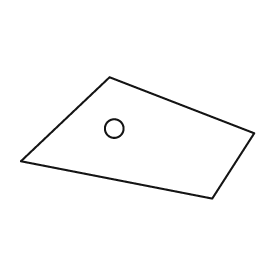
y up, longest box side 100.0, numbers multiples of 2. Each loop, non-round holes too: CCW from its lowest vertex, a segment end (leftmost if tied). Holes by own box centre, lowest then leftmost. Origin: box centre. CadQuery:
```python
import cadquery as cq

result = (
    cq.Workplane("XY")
    .moveTo(32.0, -26.0)
    .lineTo(50.0, 2.0)
    .lineTo(-12.0, 26.0)
    .lineTo(-50.0, -10.0)
    .close()
    .moveTo(-10.0, 4.0)
    .circle(4.0)
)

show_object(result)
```